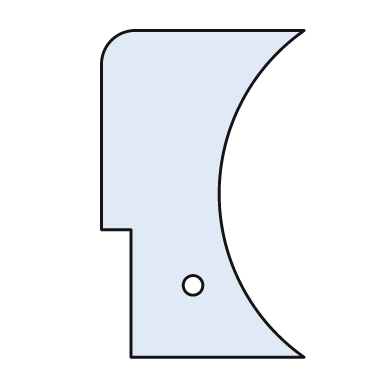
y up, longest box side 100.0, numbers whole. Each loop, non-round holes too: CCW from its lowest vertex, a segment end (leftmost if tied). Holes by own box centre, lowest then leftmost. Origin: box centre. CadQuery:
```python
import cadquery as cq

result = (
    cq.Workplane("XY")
    .moveTo(-22.0, -50.0)
    .lineTo(31.0, -50.0)
    .threePointArc((5.0, 0.0), (31.0, 50.0))
    .lineTo(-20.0, 50.0)
    .threePointArc((-28.0, 47.0), (-31.0, 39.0))
    .lineTo(-31.0, -11.0)
    .lineTo(-22.0, -11.0)
    .close()
    .moveTo(-3.0, -28.0)
    .circle(3.0)
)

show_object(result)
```